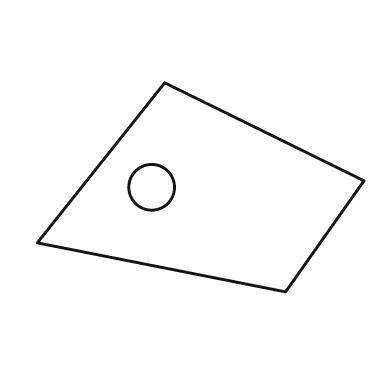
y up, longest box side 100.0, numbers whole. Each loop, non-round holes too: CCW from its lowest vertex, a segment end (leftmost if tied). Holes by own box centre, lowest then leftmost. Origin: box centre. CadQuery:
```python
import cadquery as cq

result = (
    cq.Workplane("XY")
    .moveTo(26.0, -32.0)
    .lineTo(50.0, 2.0)
    .lineTo(-11.0, 32.0)
    .lineTo(-50.0, -17.0)
    .close()
    .moveTo(-15.0, 0.0)
    .circle(7.0)
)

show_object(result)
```